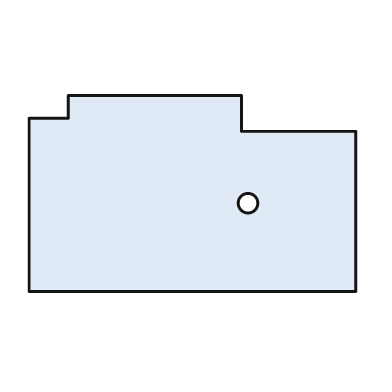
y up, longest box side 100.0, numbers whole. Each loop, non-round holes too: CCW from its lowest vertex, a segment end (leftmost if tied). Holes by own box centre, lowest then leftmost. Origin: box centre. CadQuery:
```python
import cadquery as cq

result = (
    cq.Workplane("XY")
    .moveTo(-50.0, -30.0)
    .lineTo(50.0, -30.0)
    .lineTo(50.0, 19.0)
    .lineTo(15.0, 19.0)
    .lineTo(15.0, 30.0)
    .lineTo(-38.0, 30.0)
    .lineTo(-38.0, 23.0)
    .lineTo(-50.0, 23.0)
    .close()
    .moveTo(17.0, -3.0)
    .circle(3.0)
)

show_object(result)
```